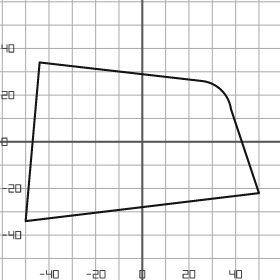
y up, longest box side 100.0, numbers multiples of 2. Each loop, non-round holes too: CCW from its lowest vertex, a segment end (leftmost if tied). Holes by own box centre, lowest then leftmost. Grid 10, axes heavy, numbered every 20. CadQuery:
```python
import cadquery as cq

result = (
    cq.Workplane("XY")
    .moveTo(-50.0, -34.0)
    .lineTo(50.0, -22.0)
    .lineTo(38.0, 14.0)
    .threePointArc((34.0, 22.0), (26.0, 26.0))
    .lineTo(-44.0, 34.0)
    .close()
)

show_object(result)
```